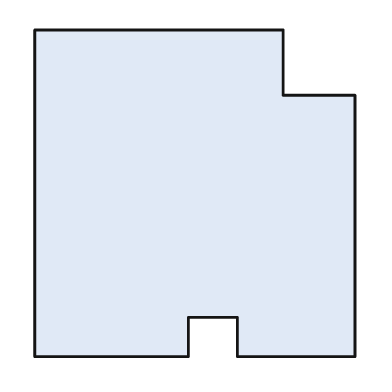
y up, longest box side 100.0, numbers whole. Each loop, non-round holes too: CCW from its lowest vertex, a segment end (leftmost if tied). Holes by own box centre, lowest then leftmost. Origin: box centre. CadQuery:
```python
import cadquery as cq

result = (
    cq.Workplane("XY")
    .moveTo(-49.0, -50.0)
    .lineTo(-2.0, -50.0)
    .lineTo(-2.0, -38.0)
    .lineTo(13.0, -38.0)
    .lineTo(13.0, -50.0)
    .lineTo(49.0, -50.0)
    .lineTo(49.0, 30.0)
    .lineTo(27.0, 30.0)
    .lineTo(27.0, 50.0)
    .lineTo(-49.0, 50.0)
    .close()
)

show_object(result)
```